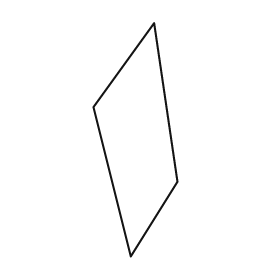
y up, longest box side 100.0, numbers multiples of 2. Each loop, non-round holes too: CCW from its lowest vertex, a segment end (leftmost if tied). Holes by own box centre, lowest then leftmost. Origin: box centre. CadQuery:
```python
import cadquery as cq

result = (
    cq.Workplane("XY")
    .moveTo(-2.0, -50.0)
    .lineTo(18.0, -18.0)
    .lineTo(8.0, 50.0)
    .lineTo(-18.0, 14.0)
    .close()
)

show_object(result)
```